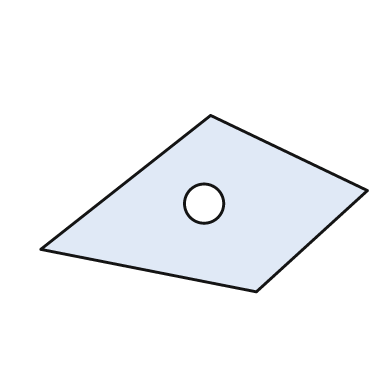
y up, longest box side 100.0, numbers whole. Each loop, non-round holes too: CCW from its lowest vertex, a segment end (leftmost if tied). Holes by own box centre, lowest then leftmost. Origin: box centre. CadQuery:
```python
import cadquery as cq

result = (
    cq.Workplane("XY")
    .moveTo(16.0, -27.0)
    .lineTo(50.0, 4.0)
    .lineTo(2.0, 27.0)
    .lineTo(-50.0, -14.0)
    .close()
    .moveTo(0.0, 0.0)
    .circle(6.0)
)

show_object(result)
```